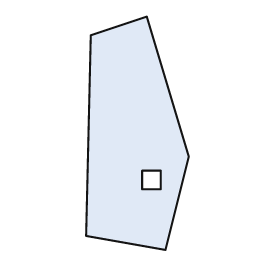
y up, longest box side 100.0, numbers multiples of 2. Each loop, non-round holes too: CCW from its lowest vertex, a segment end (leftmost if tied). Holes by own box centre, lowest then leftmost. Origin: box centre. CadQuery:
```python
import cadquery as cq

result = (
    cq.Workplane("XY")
    .moveTo(12.0, -50.0)
    .lineTo(22.0, -10.0)
    .lineTo(4.0, 50.0)
    .lineTo(-20.0, 42.0)
    .lineTo(-22.0, -44.0)
    .close()
    .moveTo(2.0, -24.0)
    .lineTo(10.0, -24.0)
    .lineTo(10.0, -16.0)
    .lineTo(2.0, -16.0)
    .close()
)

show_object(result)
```